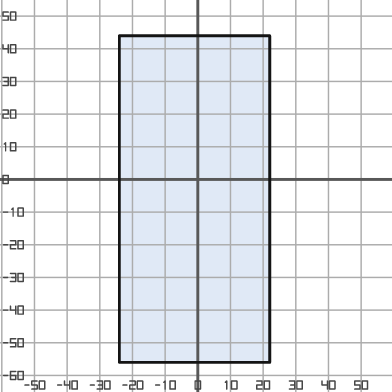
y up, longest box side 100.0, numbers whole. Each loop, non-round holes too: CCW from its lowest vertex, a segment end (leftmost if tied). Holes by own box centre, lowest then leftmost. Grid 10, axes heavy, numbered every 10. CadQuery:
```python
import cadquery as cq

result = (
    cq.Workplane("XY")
    .moveTo(-24.0, -56.0)
    .lineTo(22.0, -56.0)
    .lineTo(22.0, 44.0)
    .lineTo(-24.0, 44.0)
    .close()
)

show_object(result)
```